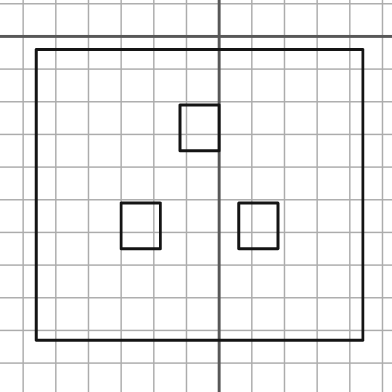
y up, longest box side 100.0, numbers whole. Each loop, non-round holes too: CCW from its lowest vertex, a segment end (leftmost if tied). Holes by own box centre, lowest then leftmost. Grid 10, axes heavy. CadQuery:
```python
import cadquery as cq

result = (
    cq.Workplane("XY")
    .moveTo(-56.0, -93.0)
    .lineTo(44.0, -93.0)
    .lineTo(44.0, -4.0)
    .lineTo(-56.0, -4.0)
    .close()
    .moveTo(-30.0, -65.0)
    .lineTo(-18.0, -65.0)
    .lineTo(-18.0, -51.0)
    .lineTo(-30.0, -51.0)
    .close()
    .moveTo(6.0, -65.0)
    .lineTo(18.0, -65.0)
    .lineTo(18.0, -51.0)
    .lineTo(6.0, -51.0)
    .close()
    .moveTo(-12.0, -35.0)
    .lineTo(0.0, -35.0)
    .lineTo(0.0, -21.0)
    .lineTo(-12.0, -21.0)
    .close()
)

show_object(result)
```